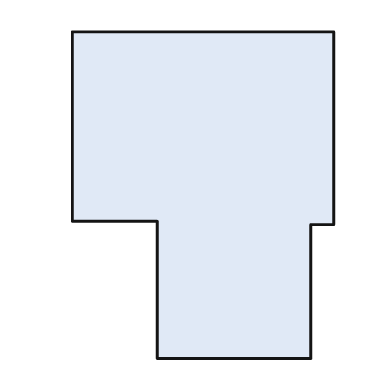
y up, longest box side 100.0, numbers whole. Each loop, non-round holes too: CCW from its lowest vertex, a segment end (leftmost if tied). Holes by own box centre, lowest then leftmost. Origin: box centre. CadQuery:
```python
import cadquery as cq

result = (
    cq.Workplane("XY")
    .moveTo(-14.0, -50.0)
    .lineTo(33.0, -50.0)
    .lineTo(33.0, -9.0)
    .lineTo(40.0, -9.0)
    .lineTo(40.0, 50.0)
    .lineTo(-40.0, 50.0)
    .lineTo(-40.0, -8.0)
    .lineTo(-14.0, -8.0)
    .close()
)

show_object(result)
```